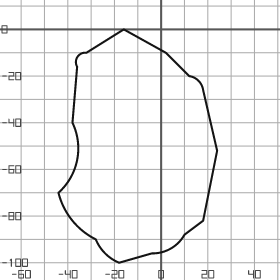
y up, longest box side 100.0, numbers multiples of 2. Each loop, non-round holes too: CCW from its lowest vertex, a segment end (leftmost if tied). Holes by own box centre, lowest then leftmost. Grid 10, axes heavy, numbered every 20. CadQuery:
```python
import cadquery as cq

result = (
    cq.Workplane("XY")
    .moveTo(-18.0, -100.0)
    .lineTo(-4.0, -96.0)
    .threePointArc((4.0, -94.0), (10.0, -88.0))
    .lineTo(18.0, -82.0)
    .lineTo(24.0, -52.0)
    .lineTo(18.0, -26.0)
    .threePointArc((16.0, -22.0), (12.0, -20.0))
    .lineTo(2.0, -10.0)
    .lineTo(-16.0, 0.0)
    .lineTo(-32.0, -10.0)
    .threePointArc((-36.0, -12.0), (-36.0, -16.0))
    .lineTo(-38.0, -40.0)
    .threePointArc((-36.0, -56.0), (-44.0, -70.0))
    .threePointArc((-38.0, -82.0), (-28.0, -90.0))
    .threePointArc((-24.0, -96.0), (-18.0, -100.0))
    .close()
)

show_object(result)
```